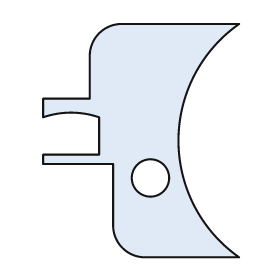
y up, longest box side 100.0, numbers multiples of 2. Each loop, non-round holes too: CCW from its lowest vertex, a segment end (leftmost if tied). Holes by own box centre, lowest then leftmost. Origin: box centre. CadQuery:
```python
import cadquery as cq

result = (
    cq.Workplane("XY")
    .moveTo(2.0, -50.0)
    .lineTo(42.0, -50.0)
    .threePointArc((16.0, 0.0), (42.0, 50.0))
    .lineTo(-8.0, 50.0)
    .threePointArc((-18.0, 46.0), (-22.0, 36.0))
    .lineTo(-22.0, 18.0)
    .lineTo(-42.0, 18.0)
    .lineTo(-42.0, 10.0)
    .threePointArc((-30.0, 12.0), (-18.0, 10.0))
    .lineTo(-18.0, -6.0)
    .lineTo(-42.0, -6.0)
    .lineTo(-42.0, -10.0)
    .lineTo(-12.0, -10.0)
    .lineTo(-12.0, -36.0)
    .threePointArc((-8.0, -46.0), (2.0, -50.0))
    .close()
    .moveTo(4.0, -16.0)
    .circle(8.0)
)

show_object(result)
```